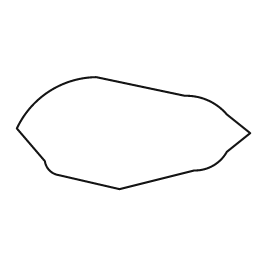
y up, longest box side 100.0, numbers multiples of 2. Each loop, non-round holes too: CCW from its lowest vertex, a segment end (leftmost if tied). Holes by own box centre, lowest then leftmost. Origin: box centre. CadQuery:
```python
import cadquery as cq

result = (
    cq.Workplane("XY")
    .moveTo(-6.0, -24.0)
    .lineTo(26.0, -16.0)
    .threePointArc((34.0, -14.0), (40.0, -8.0))
    .lineTo(50.0, 0.0)
    .lineTo(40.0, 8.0)
    .threePointArc((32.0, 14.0), (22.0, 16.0))
    .lineTo(-16.0, 24.0)
    .threePointArc((-36.0, 18.0), (-50.0, 2.0))
    .lineTo(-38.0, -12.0)
    .threePointArc((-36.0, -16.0), (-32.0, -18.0))
    .close()
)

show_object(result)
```